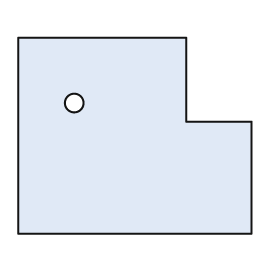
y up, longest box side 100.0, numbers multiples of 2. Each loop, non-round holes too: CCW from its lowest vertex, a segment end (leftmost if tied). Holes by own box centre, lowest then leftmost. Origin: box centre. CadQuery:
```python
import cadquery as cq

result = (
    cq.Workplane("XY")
    .moveTo(-50.0, -42.0)
    .lineTo(50.0, -42.0)
    .lineTo(50.0, 6.0)
    .lineTo(22.0, 6.0)
    .lineTo(22.0, 42.0)
    .lineTo(-50.0, 42.0)
    .close()
    .moveTo(-26.0, 14.0)
    .circle(4.0)
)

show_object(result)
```